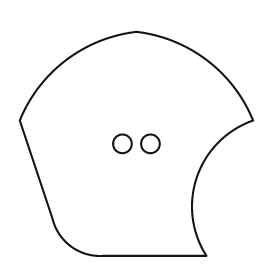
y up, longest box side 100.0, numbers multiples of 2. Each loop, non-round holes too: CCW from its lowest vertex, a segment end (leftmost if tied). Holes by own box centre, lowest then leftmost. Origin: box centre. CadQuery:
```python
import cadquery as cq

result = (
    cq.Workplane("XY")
    .moveTo(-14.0, -48.0)
    .lineTo(30.0, -48.0)
    .threePointArc((26.0, -14.0), (50.0, 10.0))
    .threePointArc((30.0, 36.0), (0.0, 48.0))
    .threePointArc((-30.0, 36.0), (-50.0, 10.0))
    .lineTo(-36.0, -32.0)
    .threePointArc((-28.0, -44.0), (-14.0, -48.0))
    .close()
    .moveTo(-6.0, 0.0)
    .circle(4.0)
    .moveTo(6.0, 0.0)
    .circle(4.0)
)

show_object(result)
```